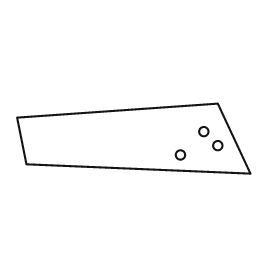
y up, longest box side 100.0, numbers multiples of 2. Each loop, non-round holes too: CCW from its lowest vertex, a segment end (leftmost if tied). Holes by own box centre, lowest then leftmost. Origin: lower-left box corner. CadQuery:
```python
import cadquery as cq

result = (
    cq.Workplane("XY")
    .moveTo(100.0, 0.0)
    .lineTo(86.0, 30.0)
    .lineTo(0.0, 24.0)
    .lineTo(4.0, 4.0)
    .close()
    .moveTo(70.0, 8.0)
    .circle(2.0)
    .moveTo(86.0, 12.0)
    .circle(2.0)
    .moveTo(80.0, 18.0)
    .circle(2.0)
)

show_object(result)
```